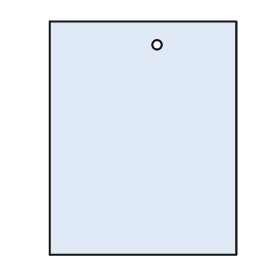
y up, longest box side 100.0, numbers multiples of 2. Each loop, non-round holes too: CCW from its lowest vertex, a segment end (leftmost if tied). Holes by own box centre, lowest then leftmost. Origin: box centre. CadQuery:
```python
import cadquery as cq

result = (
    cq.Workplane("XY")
    .moveTo(-40.0, -50.0)
    .lineTo(40.0, -50.0)
    .lineTo(40.0, 50.0)
    .lineTo(-40.0, 50.0)
    .close()
    .moveTo(6.0, 40.0)
    .circle(2.0)
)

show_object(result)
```